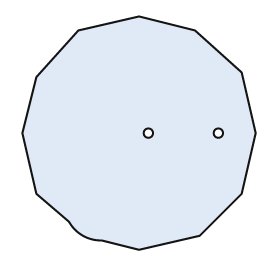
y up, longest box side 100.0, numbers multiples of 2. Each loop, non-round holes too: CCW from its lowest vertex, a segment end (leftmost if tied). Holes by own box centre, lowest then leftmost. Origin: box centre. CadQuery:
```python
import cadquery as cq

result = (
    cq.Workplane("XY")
    .moveTo(0.0, -50.0)
    .lineTo(26.0, -44.0)
    .lineTo(44.0, -26.0)
    .lineTo(50.0, 0.0)
    .lineTo(44.0, 26.0)
    .lineTo(24.0, 44.0)
    .lineTo(0.0, 50.0)
    .lineTo(-26.0, 44.0)
    .lineTo(-44.0, 24.0)
    .lineTo(-50.0, 0.0)
    .lineTo(-44.0, -26.0)
    .lineTo(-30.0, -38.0)
    .threePointArc((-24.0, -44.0), (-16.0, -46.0))
    .close()
    .moveTo(4.0, 0.0)
    .circle(2.0)
    .moveTo(34.0, 0.0)
    .circle(2.0)
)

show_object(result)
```